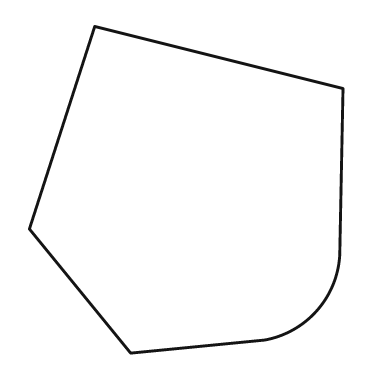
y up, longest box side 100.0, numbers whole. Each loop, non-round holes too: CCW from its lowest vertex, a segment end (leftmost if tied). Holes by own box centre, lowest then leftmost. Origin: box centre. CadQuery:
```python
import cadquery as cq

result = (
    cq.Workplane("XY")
    .moveTo(-17.0, -50.0)
    .lineTo(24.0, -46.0)
    .threePointArc((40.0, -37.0), (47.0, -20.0))
    .lineTo(48.0, 31.0)
    .lineTo(-28.0, 50.0)
    .lineTo(-48.0, -12.0)
    .close()
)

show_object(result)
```